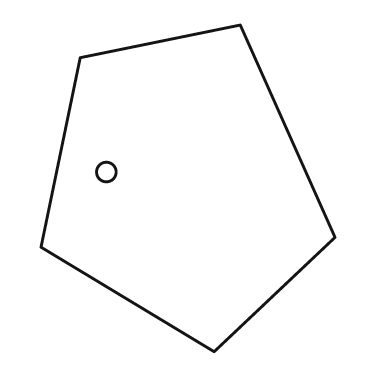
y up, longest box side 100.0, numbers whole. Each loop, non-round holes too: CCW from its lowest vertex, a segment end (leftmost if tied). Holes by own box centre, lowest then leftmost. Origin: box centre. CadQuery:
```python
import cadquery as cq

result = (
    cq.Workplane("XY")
    .moveTo(8.0, -50.0)
    .lineTo(45.0, -15.0)
    .lineTo(16.0, 50.0)
    .lineTo(-33.0, 40.0)
    .lineTo(-45.0, -18.0)
    .close()
    .moveTo(-25.0, 5.0)
    .circle(3.0)
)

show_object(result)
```